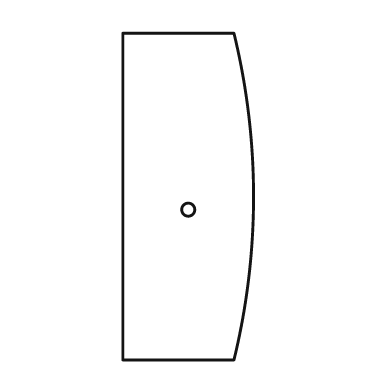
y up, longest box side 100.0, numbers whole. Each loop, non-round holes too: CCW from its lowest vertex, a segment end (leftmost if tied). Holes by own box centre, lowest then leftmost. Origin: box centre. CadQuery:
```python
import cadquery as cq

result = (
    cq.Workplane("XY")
    .moveTo(-20.0, -50.0)
    .lineTo(14.0, -50.0)
    .threePointArc((20.0, 0.0), (14.0, 50.0))
    .lineTo(-20.0, 50.0)
    .close()
    .moveTo(0.0, -4.0)
    .circle(2.0)
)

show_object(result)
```